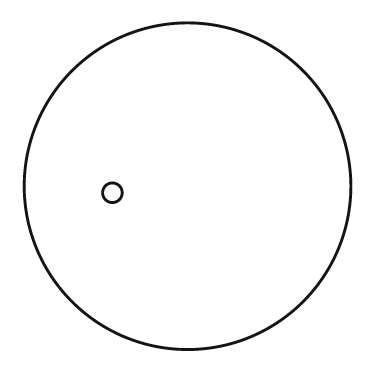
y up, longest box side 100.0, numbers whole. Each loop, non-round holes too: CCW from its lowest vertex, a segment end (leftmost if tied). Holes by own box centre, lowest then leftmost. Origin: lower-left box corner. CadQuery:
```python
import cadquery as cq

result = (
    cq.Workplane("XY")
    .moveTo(50.0, 50.0)
    .circle(50.0)
    .moveTo(27.0, 48.0)
    .circle(3.0)
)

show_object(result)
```